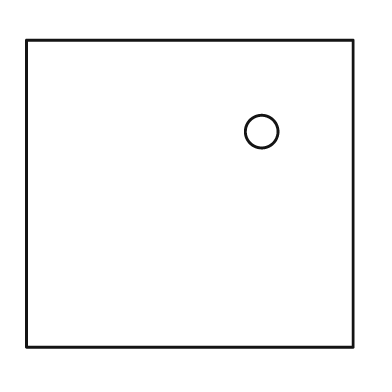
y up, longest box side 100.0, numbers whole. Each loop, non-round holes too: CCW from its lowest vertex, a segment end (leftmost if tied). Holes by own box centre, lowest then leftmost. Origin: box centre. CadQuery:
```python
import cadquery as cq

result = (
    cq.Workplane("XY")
    .moveTo(-50.0, -47.0)
    .lineTo(50.0, -47.0)
    .lineTo(50.0, 47.0)
    .lineTo(-50.0, 47.0)
    .close()
    .moveTo(22.0, 19.0)
    .circle(5.0)
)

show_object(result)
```